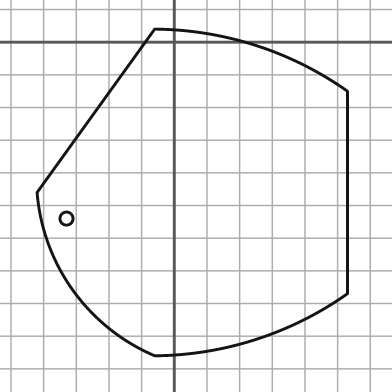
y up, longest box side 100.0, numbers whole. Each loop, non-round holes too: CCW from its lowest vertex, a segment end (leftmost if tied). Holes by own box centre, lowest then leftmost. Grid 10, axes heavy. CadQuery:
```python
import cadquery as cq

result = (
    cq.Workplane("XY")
    .moveTo(-6.0, -96.0)
    .threePointArc((25.0, -91.0), (53.0, -77.0))
    .lineTo(53.0, -15.0)
    .threePointArc((25.0, -1.0), (-6.0, 4.0))
    .lineTo(-42.0, -46.0)
    .threePointArc((-31.0, -76.0), (-6.0, -96.0))
    .close()
    .moveTo(-33.0, -54.0)
    .circle(2.0)
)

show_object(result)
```